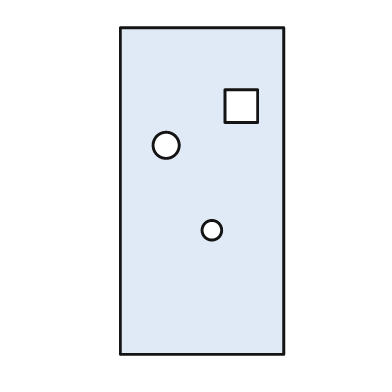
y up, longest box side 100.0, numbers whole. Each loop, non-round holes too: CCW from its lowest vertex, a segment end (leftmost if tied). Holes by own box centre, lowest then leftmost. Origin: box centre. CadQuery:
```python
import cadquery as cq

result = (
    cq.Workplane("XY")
    .moveTo(-25.0, -50.0)
    .lineTo(25.0, -50.0)
    .lineTo(25.0, 50.0)
    .lineTo(-25.0, 50.0)
    .close()
    .moveTo(3.0, -12.0)
    .circle(3.0)
    .moveTo(-11.0, 14.0)
    .circle(4.0)
    .moveTo(7.0, 21.0)
    .lineTo(17.0, 21.0)
    .lineTo(17.0, 31.0)
    .lineTo(7.0, 31.0)
    .close()
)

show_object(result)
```